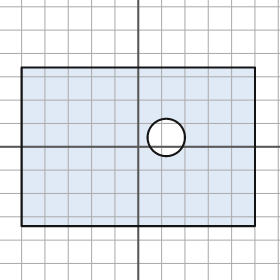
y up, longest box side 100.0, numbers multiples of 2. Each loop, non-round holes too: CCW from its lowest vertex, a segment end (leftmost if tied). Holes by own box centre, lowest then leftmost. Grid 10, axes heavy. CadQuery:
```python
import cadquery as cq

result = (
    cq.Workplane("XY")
    .moveTo(-50.0, -34.0)
    .lineTo(50.0, -34.0)
    .lineTo(50.0, 34.0)
    .lineTo(-50.0, 34.0)
    .close()
    .moveTo(12.0, 4.0)
    .circle(8.0)
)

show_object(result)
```